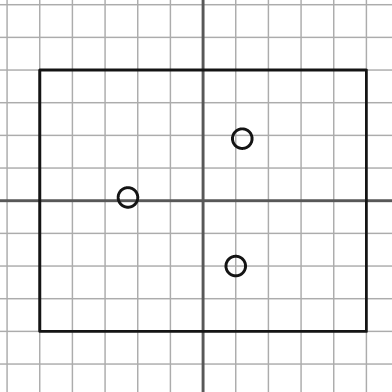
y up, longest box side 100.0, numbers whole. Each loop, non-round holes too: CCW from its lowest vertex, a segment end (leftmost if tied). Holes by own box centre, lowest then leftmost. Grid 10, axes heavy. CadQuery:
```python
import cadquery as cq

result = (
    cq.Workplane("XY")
    .moveTo(-50.0, -40.0)
    .lineTo(50.0, -40.0)
    .lineTo(50.0, 40.0)
    .lineTo(-50.0, 40.0)
    .close()
    .moveTo(10.0, -20.0)
    .circle(3.0)
    .moveTo(-23.0, 1.0)
    .circle(3.0)
    .moveTo(12.0, 19.0)
    .circle(3.0)
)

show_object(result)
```